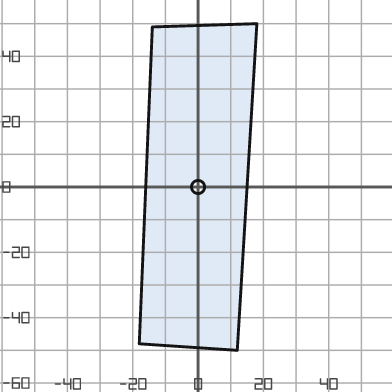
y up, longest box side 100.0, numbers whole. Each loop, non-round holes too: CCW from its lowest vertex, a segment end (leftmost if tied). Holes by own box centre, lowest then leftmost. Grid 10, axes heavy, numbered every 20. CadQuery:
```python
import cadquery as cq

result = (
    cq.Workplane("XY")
    .moveTo(12.0, -50.0)
    .lineTo(18.0, 50.0)
    .lineTo(-14.0, 49.0)
    .lineTo(-18.0, -48.0)
    .close()
    .moveTo(0.0, 0.0)
    .circle(2.0)
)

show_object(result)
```